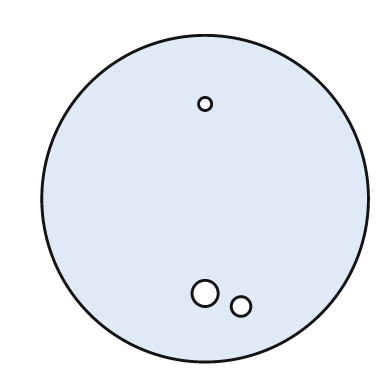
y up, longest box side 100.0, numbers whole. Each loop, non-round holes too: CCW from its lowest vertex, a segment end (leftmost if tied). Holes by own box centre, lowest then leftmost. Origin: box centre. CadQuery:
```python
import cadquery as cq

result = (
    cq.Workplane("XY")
    .moveTo(0.0, 0.0)
    .circle(50.0)
    .moveTo(11.0, -33.0)
    .circle(3.0)
    .moveTo(0.0, -29.0)
    .circle(4.0)
    .moveTo(0.0, 29.0)
    .circle(2.0)
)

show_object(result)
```